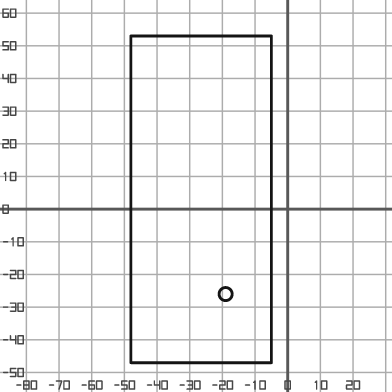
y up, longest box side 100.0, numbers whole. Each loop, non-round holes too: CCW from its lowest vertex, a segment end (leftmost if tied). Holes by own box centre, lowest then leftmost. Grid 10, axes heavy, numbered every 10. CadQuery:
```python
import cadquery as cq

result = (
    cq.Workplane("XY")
    .moveTo(-48.0, -47.0)
    .lineTo(-5.0, -47.0)
    .lineTo(-5.0, 53.0)
    .lineTo(-48.0, 53.0)
    .close()
    .moveTo(-19.0, -26.0)
    .circle(2.0)
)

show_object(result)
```